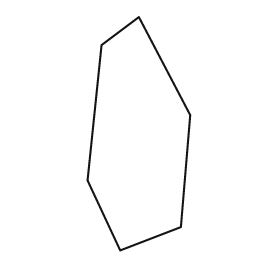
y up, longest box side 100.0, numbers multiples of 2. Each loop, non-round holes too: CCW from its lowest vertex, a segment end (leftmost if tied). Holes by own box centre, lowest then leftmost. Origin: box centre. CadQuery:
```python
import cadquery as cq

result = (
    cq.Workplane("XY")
    .moveTo(-8.0, -50.0)
    .lineTo(18.0, -40.0)
    .lineTo(22.0, 8.0)
    .lineTo(0.0, 50.0)
    .lineTo(-16.0, 38.0)
    .lineTo(-22.0, -20.0)
    .close()
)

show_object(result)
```